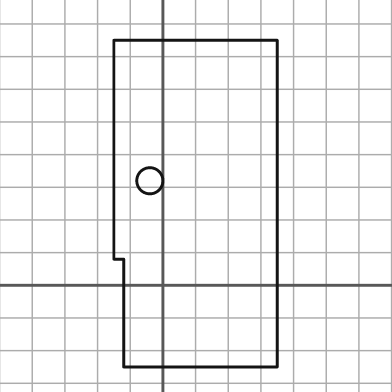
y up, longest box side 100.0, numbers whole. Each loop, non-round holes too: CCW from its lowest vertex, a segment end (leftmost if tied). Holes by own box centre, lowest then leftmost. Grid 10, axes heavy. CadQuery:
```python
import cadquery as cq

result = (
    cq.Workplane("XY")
    .moveTo(-12.0, -25.0)
    .lineTo(35.0, -25.0)
    .lineTo(35.0, 75.0)
    .lineTo(-15.0, 75.0)
    .lineTo(-15.0, 8.0)
    .lineTo(-12.0, 8.0)
    .close()
    .moveTo(-4.0, 32.0)
    .circle(4.0)
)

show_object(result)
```